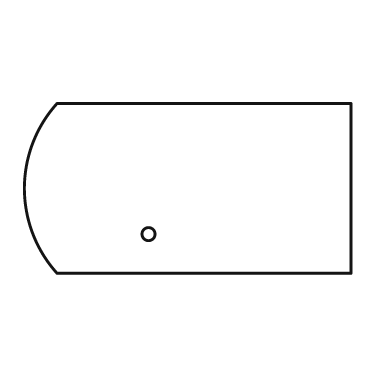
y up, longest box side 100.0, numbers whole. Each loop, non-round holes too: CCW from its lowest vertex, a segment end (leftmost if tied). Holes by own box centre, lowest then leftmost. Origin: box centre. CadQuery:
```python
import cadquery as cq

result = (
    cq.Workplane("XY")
    .moveTo(-40.0, -26.0)
    .lineTo(50.0, -26.0)
    .lineTo(50.0, 26.0)
    .lineTo(-40.0, 26.0)
    .threePointArc((-50.0, 0.0), (-40.0, -26.0))
    .close()
    .moveTo(-12.0, -14.0)
    .circle(2.0)
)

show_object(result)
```